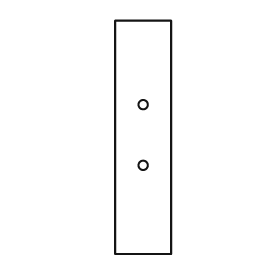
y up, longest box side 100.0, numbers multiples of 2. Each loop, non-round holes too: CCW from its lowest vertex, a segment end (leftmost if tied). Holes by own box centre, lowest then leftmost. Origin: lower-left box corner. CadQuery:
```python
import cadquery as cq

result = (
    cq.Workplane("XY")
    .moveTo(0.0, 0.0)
    .lineTo(24.0, 0.0)
    .lineTo(24.0, 100.0)
    .lineTo(0.0, 100.0)
    .close()
    .moveTo(12.0, 38.0)
    .circle(2.0)
    .moveTo(12.0, 64.0)
    .circle(2.0)
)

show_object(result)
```